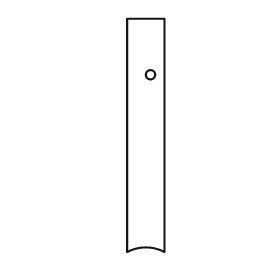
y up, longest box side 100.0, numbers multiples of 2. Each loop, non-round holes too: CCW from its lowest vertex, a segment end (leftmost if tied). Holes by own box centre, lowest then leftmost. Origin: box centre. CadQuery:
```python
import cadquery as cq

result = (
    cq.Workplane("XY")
    .moveTo(-8.0, -50.0)
    .threePointArc((0.0, -48.0), (8.0, -50.0))
    .lineTo(8.0, 50.0)
    .lineTo(-8.0, 50.0)
    .close()
    .moveTo(2.0, 26.0)
    .circle(2.0)
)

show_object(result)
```